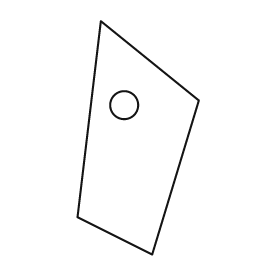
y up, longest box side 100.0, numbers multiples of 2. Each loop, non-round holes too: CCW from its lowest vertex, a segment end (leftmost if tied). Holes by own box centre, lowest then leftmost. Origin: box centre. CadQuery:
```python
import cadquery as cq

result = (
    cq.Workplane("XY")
    .moveTo(6.0, -50.0)
    .lineTo(26.0, 16.0)
    .lineTo(-16.0, 50.0)
    .lineTo(-26.0, -34.0)
    .close()
    .moveTo(-6.0, 14.0)
    .circle(6.0)
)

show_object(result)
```